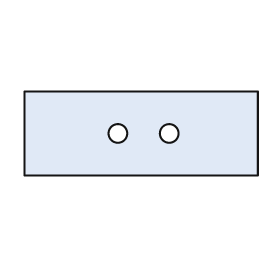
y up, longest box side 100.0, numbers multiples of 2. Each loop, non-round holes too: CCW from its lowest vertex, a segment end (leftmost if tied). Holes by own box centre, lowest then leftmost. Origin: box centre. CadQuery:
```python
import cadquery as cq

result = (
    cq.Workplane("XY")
    .moveTo(-50.0, -18.0)
    .lineTo(50.0, -18.0)
    .lineTo(50.0, 18.0)
    .lineTo(-50.0, 18.0)
    .close()
    .moveTo(-10.0, 0.0)
    .circle(4.0)
    .moveTo(12.0, 0.0)
    .circle(4.0)
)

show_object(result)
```